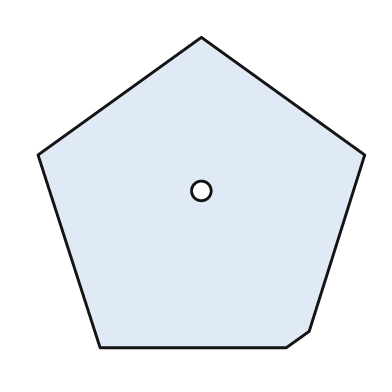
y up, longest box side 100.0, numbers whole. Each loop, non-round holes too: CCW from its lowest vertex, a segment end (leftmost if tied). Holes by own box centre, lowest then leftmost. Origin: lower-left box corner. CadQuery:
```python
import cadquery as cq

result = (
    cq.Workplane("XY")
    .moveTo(19.0, 0.0)
    .lineTo(76.0, 0.0)
    .lineTo(83.0, 5.0)
    .lineTo(100.0, 59.0)
    .lineTo(50.0, 95.0)
    .lineTo(0.0, 59.0)
    .close()
    .moveTo(50.0, 48.0)
    .circle(3.0)
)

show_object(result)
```